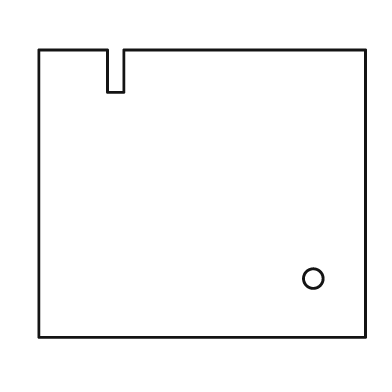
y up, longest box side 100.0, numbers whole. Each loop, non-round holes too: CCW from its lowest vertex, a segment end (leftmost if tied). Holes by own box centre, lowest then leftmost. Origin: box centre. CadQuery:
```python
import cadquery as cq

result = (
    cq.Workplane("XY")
    .moveTo(-50.0, -44.0)
    .lineTo(50.0, -44.0)
    .lineTo(50.0, 44.0)
    .lineTo(-24.0, 44.0)
    .lineTo(-24.0, 31.0)
    .lineTo(-29.0, 31.0)
    .lineTo(-29.0, 44.0)
    .lineTo(-50.0, 44.0)
    .close()
    .moveTo(34.0, -26.0)
    .circle(3.0)
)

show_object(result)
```